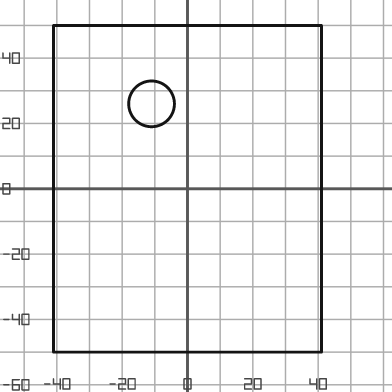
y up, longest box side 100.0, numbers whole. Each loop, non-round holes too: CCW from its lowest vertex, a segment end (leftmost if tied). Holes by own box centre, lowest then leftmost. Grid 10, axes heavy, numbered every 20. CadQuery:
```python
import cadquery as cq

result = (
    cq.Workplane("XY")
    .moveTo(-41.0, -50.0)
    .lineTo(41.0, -50.0)
    .lineTo(41.0, 50.0)
    .lineTo(-41.0, 50.0)
    .close()
    .moveTo(-11.0, 26.0)
    .circle(7.0)
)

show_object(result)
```